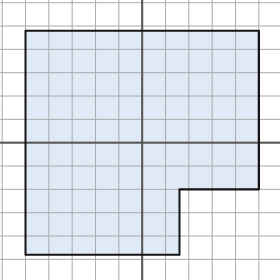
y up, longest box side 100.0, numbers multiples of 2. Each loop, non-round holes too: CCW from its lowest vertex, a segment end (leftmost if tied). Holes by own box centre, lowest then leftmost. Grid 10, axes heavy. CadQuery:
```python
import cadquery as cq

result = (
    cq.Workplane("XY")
    .moveTo(-50.0, -48.0)
    .lineTo(16.0, -48.0)
    .lineTo(16.0, -20.0)
    .lineTo(50.0, -20.0)
    .lineTo(50.0, 48.0)
    .lineTo(-50.0, 48.0)
    .close()
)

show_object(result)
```